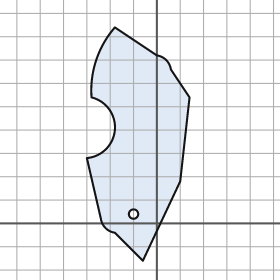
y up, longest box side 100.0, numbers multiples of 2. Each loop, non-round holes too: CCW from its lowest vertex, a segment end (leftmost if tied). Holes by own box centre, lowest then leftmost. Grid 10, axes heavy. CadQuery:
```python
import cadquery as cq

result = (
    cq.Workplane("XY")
    .moveTo(-6.0, -16.0)
    .lineTo(10.0, 18.0)
    .lineTo(14.0, 54.0)
    .lineTo(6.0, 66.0)
    .threePointArc((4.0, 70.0), (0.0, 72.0))
    .lineTo(-18.0, 84.0)
    .threePointArc((-26.0, 70.0), (-28.0, 54.0))
    .threePointArc((-18.0, 40.0), (-30.0, 28.0))
    .lineTo(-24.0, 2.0)
    .threePointArc((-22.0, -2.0), (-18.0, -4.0))
    .close()
    .moveTo(-10.0, 4.0)
    .circle(2.0)
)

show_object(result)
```